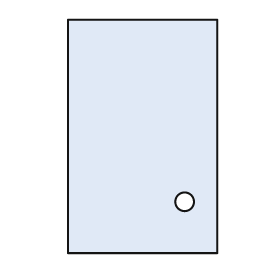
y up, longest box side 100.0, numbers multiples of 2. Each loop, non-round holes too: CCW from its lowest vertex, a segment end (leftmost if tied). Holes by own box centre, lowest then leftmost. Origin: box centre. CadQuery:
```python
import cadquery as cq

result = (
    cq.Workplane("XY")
    .moveTo(-32.0, -50.0)
    .lineTo(32.0, -50.0)
    .lineTo(32.0, 50.0)
    .lineTo(-32.0, 50.0)
    .close()
    .moveTo(18.0, -28.0)
    .circle(4.0)
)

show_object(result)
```